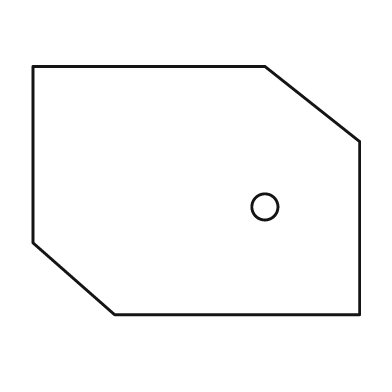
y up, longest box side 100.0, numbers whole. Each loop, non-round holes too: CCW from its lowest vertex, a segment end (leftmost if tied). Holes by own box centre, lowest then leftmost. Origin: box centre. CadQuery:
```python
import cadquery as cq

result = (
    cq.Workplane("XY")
    .moveTo(-25.0, -38.0)
    .lineTo(50.0, -38.0)
    .lineTo(50.0, 15.0)
    .lineTo(21.0, 38.0)
    .lineTo(-50.0, 38.0)
    .lineTo(-50.0, -16.0)
    .close()
    .moveTo(21.0, -5.0)
    .circle(4.0)
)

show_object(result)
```